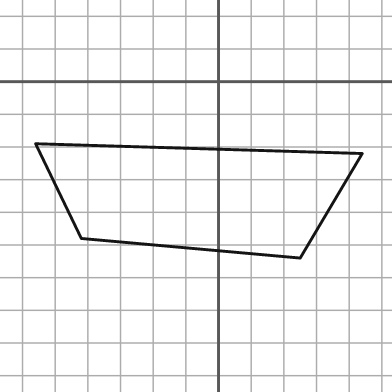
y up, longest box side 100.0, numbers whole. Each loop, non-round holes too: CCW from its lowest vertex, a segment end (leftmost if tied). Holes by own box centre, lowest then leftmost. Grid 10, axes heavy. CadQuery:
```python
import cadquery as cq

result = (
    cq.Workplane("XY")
    .moveTo(25.0, -54.0)
    .lineTo(44.0, -22.0)
    .lineTo(-56.0, -19.0)
    .lineTo(-42.0, -48.0)
    .close()
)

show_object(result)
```